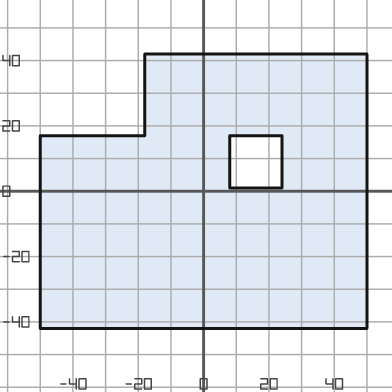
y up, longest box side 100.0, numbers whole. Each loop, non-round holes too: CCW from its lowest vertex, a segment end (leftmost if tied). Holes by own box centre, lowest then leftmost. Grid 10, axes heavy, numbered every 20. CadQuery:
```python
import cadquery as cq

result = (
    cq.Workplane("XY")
    .moveTo(-50.0, -42.0)
    .lineTo(50.0, -42.0)
    .lineTo(50.0, 42.0)
    .lineTo(-18.0, 42.0)
    .lineTo(-18.0, 17.0)
    .lineTo(-50.0, 17.0)
    .close()
    .moveTo(8.0, 1.0)
    .lineTo(24.0, 1.0)
    .lineTo(24.0, 17.0)
    .lineTo(8.0, 17.0)
    .close()
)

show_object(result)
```